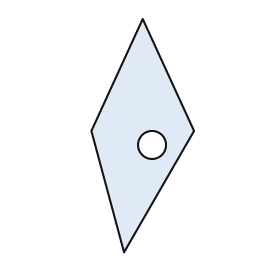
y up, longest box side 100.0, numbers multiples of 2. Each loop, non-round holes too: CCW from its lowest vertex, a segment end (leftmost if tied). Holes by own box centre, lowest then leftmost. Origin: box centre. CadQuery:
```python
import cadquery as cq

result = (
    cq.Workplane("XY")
    .moveTo(-8.0, -50.0)
    .lineTo(22.0, 2.0)
    .lineTo(0.0, 50.0)
    .lineTo(-22.0, 2.0)
    .close()
    .moveTo(4.0, -4.0)
    .circle(6.0)
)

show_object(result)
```